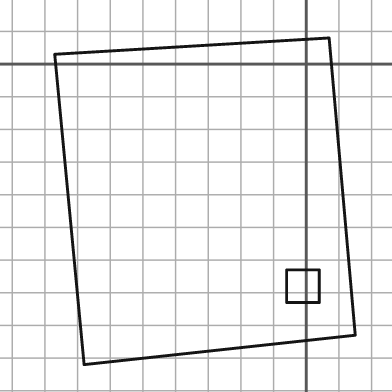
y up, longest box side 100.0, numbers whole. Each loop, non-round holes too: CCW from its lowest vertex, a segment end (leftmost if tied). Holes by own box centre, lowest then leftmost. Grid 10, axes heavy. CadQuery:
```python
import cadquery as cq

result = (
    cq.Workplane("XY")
    .moveTo(-68.0, -92.0)
    .lineTo(15.0, -83.0)
    .lineTo(7.0, 8.0)
    .lineTo(-77.0, 3.0)
    .close()
    .moveTo(-6.0, -73.0)
    .lineTo(4.0, -73.0)
    .lineTo(4.0, -63.0)
    .lineTo(-6.0, -63.0)
    .close()
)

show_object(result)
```